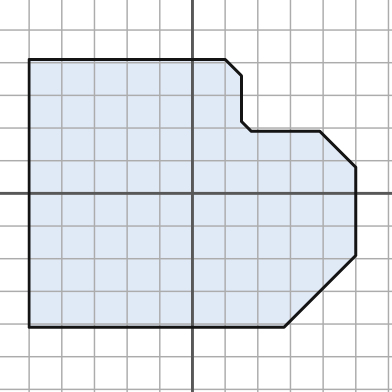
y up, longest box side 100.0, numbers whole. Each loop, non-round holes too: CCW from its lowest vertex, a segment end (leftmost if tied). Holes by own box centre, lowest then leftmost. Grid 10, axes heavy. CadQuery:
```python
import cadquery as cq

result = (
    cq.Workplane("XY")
    .moveTo(-50.0, -41.0)
    .lineTo(28.0, -41.0)
    .lineTo(50.0, -19.0)
    .lineTo(50.0, 8.0)
    .lineTo(39.0, 19.0)
    .lineTo(18.0, 19.0)
    .lineTo(15.0, 22.0)
    .lineTo(15.0, 36.0)
    .lineTo(10.0, 41.0)
    .lineTo(-50.0, 41.0)
    .close()
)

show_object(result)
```